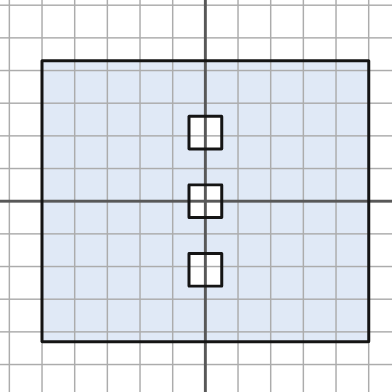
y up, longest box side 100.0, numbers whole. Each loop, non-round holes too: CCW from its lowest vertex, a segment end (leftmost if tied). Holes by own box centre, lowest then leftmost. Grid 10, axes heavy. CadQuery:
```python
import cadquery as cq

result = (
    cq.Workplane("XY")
    .moveTo(-50.0, -43.0)
    .lineTo(50.0, -43.0)
    .lineTo(50.0, 43.0)
    .lineTo(-50.0, 43.0)
    .close()
    .moveTo(-5.0, -26.0)
    .lineTo(5.0, -26.0)
    .lineTo(5.0, -16.0)
    .lineTo(-5.0, -16.0)
    .close()
    .moveTo(-5.0, -5.0)
    .lineTo(5.0, -5.0)
    .lineTo(5.0, 5.0)
    .lineTo(-5.0, 5.0)
    .close()
    .moveTo(-5.0, 16.0)
    .lineTo(5.0, 16.0)
    .lineTo(5.0, 26.0)
    .lineTo(-5.0, 26.0)
    .close()
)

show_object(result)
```